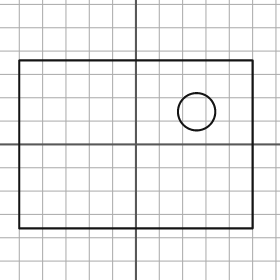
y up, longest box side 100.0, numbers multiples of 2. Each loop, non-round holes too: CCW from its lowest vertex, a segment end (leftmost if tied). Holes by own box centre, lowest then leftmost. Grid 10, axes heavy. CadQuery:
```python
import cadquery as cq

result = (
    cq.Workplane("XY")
    .moveTo(-50.0, -36.0)
    .lineTo(50.0, -36.0)
    .lineTo(50.0, 36.0)
    .lineTo(-50.0, 36.0)
    .close()
    .moveTo(26.0, 14.0)
    .circle(8.0)
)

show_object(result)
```